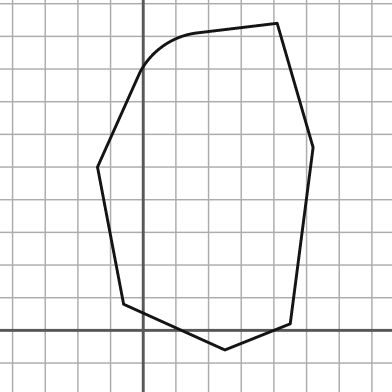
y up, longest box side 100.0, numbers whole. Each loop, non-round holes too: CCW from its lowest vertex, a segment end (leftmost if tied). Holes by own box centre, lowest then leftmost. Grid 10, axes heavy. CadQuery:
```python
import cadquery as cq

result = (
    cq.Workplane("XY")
    .moveTo(25.0, -6.0)
    .lineTo(45.0, 2.0)
    .lineTo(52.0, 56.0)
    .lineTo(41.0, 94.0)
    .lineTo(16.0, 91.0)
    .threePointArc((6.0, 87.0), (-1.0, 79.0))
    .lineTo(-14.0, 50.0)
    .lineTo(-6.0, 8.0)
    .close()
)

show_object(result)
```